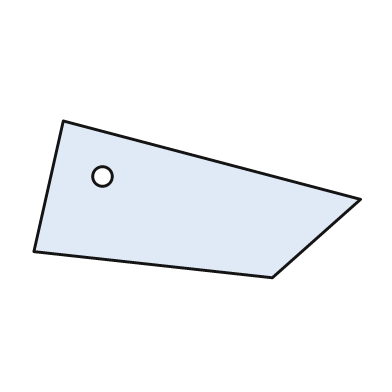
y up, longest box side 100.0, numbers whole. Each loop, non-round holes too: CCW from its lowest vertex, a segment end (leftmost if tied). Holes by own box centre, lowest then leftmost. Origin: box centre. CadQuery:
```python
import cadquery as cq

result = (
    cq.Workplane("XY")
    .moveTo(23.0, -24.0)
    .lineTo(50.0, 0.0)
    .lineTo(-41.0, 24.0)
    .lineTo(-50.0, -16.0)
    .close()
    .moveTo(-29.0, 7.0)
    .circle(3.0)
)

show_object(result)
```